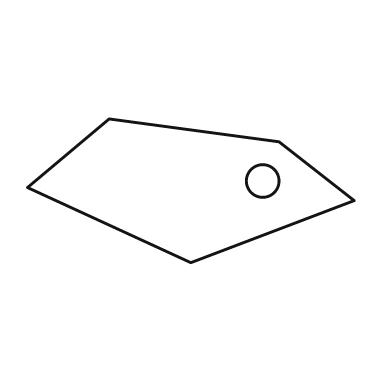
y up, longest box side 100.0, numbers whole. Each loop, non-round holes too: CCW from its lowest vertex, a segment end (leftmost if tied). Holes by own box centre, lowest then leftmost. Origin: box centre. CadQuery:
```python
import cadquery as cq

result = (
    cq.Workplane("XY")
    .moveTo(0.0, -22.0)
    .lineTo(50.0, -3.0)
    .lineTo(27.0, 15.0)
    .lineTo(-25.0, 22.0)
    .lineTo(-50.0, 1.0)
    .close()
    .moveTo(22.0, 3.0)
    .circle(5.0)
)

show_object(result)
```